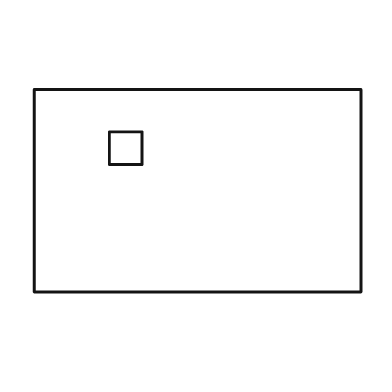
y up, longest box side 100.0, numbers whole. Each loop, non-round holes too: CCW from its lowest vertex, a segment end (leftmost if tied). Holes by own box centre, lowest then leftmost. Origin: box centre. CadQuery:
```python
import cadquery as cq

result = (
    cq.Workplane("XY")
    .moveTo(-50.0, -31.0)
    .lineTo(50.0, -31.0)
    .lineTo(50.0, 31.0)
    .lineTo(-50.0, 31.0)
    .close()
    .moveTo(-27.0, 8.0)
    .lineTo(-17.0, 8.0)
    .lineTo(-17.0, 18.0)
    .lineTo(-27.0, 18.0)
    .close()
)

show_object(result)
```